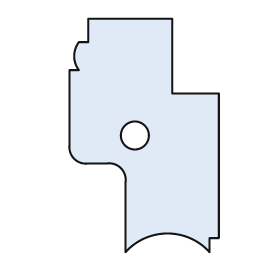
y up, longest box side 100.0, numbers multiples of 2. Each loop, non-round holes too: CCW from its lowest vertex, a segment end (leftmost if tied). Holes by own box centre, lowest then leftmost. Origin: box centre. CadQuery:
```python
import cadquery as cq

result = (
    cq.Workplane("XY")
    .moveTo(-8.0, -50.0)
    .threePointArc((10.0, -42.0), (28.0, -50.0))
    .lineTo(28.0, -44.0)
    .lineTo(32.0, -44.0)
    .lineTo(32.0, 18.0)
    .lineTo(12.0, 18.0)
    .lineTo(12.0, 50.0)
    .lineTo(-24.0, 50.0)
    .lineTo(-24.0, 40.0)
    .lineTo(-28.0, 40.0)
    .threePointArc((-30.0, 34.0), (-28.0, 28.0))
    .lineTo(-32.0, 28.0)
    .lineTo(-32.0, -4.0)
    .threePointArc((-30.0, -10.0), (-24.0, -12.0))
    .lineTo(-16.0, -12.0)
    .threePointArc((-10.0, -14.0), (-8.0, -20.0))
    .close()
    .moveTo(-4.0, 0.0)
    .circle(6.0)
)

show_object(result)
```